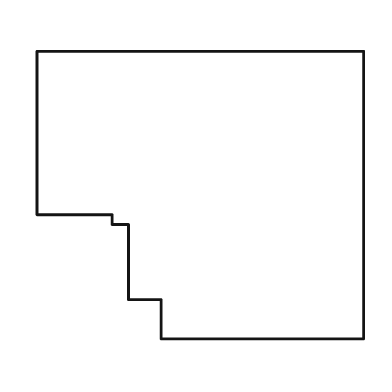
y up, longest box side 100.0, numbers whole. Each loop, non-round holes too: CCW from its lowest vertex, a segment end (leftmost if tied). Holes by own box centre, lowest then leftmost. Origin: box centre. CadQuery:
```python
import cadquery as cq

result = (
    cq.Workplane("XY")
    .moveTo(-12.0, -44.0)
    .lineTo(50.0, -44.0)
    .lineTo(50.0, 44.0)
    .lineTo(-50.0, 44.0)
    .lineTo(-50.0, -6.0)
    .lineTo(-27.0, -6.0)
    .lineTo(-27.0, -9.0)
    .lineTo(-22.0, -9.0)
    .lineTo(-22.0, -32.0)
    .lineTo(-12.0, -32.0)
    .close()
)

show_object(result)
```